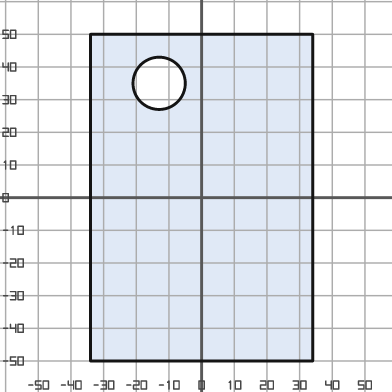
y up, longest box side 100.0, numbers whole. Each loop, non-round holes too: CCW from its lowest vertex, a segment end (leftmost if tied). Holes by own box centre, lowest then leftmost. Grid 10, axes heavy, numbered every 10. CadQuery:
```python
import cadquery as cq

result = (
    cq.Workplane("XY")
    .moveTo(-34.0, -50.0)
    .lineTo(34.0, -50.0)
    .lineTo(34.0, 50.0)
    .lineTo(-34.0, 50.0)
    .close()
    .moveTo(-13.0, 35.0)
    .circle(8.0)
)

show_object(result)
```